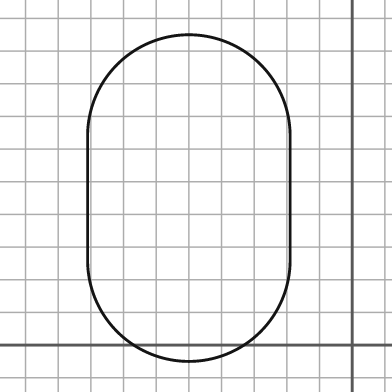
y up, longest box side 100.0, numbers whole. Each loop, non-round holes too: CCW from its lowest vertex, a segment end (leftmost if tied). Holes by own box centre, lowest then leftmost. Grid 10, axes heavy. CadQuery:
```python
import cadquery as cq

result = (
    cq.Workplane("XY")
    .moveTo(-81.0, 26.0)
    .threePointArc((-50.0, -5.0), (-19.0, 26.0))
    .lineTo(-19.0, 64.0)
    .threePointArc((-50.0, 95.0), (-81.0, 64.0))
    .close()
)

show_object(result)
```